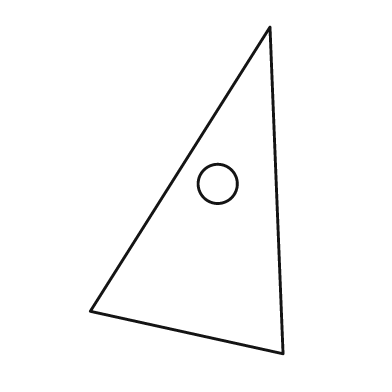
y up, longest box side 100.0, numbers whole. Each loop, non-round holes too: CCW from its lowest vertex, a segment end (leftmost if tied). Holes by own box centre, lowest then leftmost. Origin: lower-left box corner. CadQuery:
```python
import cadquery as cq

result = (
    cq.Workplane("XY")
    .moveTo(59.0, 0.0)
    .lineTo(55.0, 100.0)
    .lineTo(0.0, 13.0)
    .close()
    .moveTo(39.0, 52.0)
    .circle(6.0)
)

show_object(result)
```